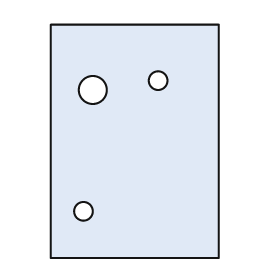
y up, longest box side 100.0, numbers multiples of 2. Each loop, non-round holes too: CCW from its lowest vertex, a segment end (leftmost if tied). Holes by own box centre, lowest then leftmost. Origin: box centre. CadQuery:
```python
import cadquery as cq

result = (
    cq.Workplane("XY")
    .moveTo(-36.0, -50.0)
    .lineTo(36.0, -50.0)
    .lineTo(36.0, 50.0)
    .lineTo(-36.0, 50.0)
    .close()
    .moveTo(-22.0, -30.0)
    .circle(4.0)
    .moveTo(-18.0, 22.0)
    .circle(6.0)
    .moveTo(10.0, 26.0)
    .circle(4.0)
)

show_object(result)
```